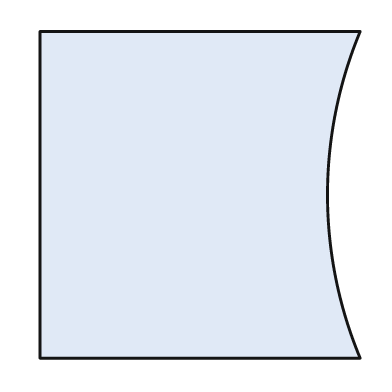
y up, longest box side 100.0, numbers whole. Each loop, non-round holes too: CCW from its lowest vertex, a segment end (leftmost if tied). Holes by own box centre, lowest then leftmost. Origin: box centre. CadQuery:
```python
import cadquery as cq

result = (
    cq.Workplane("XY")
    .moveTo(-49.0, -50.0)
    .lineTo(49.0, -50.0)
    .threePointArc((39.0, 0.0), (49.0, 50.0))
    .lineTo(-49.0, 50.0)
    .close()
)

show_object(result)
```